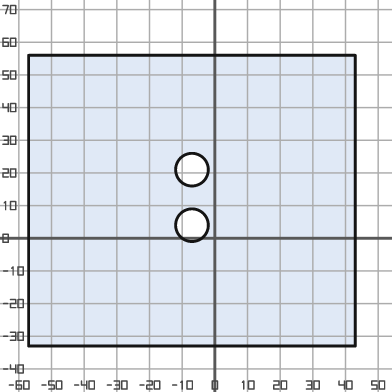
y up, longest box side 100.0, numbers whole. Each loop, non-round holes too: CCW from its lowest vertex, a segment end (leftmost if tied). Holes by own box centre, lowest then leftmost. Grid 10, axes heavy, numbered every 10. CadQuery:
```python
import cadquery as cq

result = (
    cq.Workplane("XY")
    .moveTo(-57.0, -33.0)
    .lineTo(43.0, -33.0)
    .lineTo(43.0, 56.0)
    .lineTo(-57.0, 56.0)
    .close()
    .moveTo(-7.0, 4.0)
    .circle(5.0)
    .moveTo(-7.0, 21.0)
    .circle(5.0)
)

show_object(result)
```